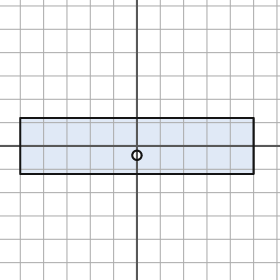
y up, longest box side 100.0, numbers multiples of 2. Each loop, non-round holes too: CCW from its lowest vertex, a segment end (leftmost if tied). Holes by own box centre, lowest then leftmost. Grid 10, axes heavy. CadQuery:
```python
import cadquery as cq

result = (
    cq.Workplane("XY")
    .moveTo(-50.0, -12.0)
    .lineTo(50.0, -12.0)
    .lineTo(50.0, 12.0)
    .lineTo(-50.0, 12.0)
    .close()
    .moveTo(0.0, -4.0)
    .circle(2.0)
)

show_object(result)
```